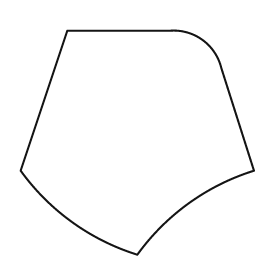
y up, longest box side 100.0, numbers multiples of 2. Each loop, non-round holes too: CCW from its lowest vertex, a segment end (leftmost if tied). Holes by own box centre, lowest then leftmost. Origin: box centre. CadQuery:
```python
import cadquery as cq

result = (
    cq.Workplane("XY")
    .moveTo(0.0, -48.0)
    .threePointArc((22.0, -26.0), (50.0, -12.0))
    .lineTo(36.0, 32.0)
    .threePointArc((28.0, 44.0), (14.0, 48.0))
    .lineTo(-30.0, 48.0)
    .lineTo(-50.0, -12.0)
    .threePointArc((-28.0, -34.0), (0.0, -48.0))
    .close()
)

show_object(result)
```